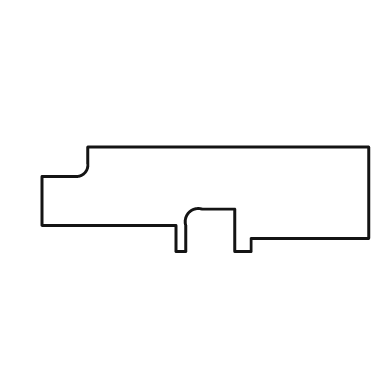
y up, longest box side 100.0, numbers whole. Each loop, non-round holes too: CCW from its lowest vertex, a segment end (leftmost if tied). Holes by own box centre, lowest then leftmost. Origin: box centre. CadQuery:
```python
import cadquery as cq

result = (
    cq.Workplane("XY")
    .moveTo(-9.0, -16.0)
    .lineTo(-6.0, -16.0)
    .lineTo(-6.0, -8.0)
    .threePointArc((-5.0, -4.0), (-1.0, -3.0))
    .lineTo(9.0, -3.0)
    .lineTo(9.0, -16.0)
    .lineTo(14.0, -16.0)
    .lineTo(14.0, -12.0)
    .lineTo(50.0, -12.0)
    .lineTo(50.0, 16.0)
    .lineTo(-36.0, 16.0)
    .lineTo(-36.0, 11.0)
    .threePointArc((-37.0, 8.0), (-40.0, 7.0))
    .lineTo(-50.0, 7.0)
    .lineTo(-50.0, -8.0)
    .lineTo(-9.0, -8.0)
    .close()
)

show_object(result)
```